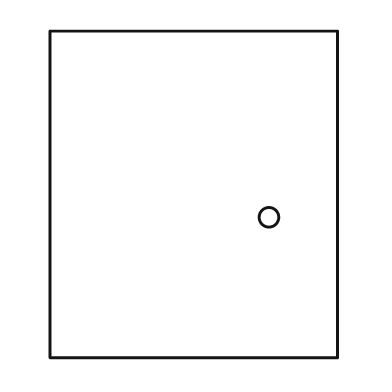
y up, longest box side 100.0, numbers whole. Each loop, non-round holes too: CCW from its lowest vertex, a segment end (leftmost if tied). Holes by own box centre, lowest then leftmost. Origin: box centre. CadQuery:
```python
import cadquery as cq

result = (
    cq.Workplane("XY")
    .moveTo(-44.0, -50.0)
    .lineTo(44.0, -50.0)
    .lineTo(44.0, 50.0)
    .lineTo(-44.0, 50.0)
    .close()
    .moveTo(23.0, -7.0)
    .circle(3.0)
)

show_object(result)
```